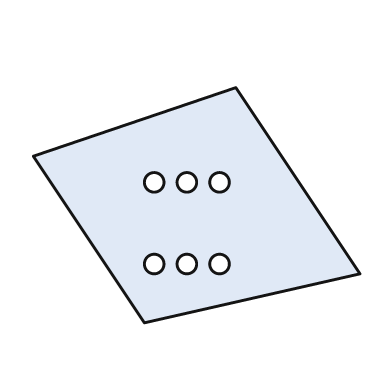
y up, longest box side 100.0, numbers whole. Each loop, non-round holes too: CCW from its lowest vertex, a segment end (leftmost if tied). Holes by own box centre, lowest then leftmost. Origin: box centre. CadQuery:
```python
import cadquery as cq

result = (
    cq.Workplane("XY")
    .moveTo(-16.0, -36.0)
    .lineTo(50.0, -21.0)
    .lineTo(12.0, 36.0)
    .lineTo(-50.0, 15.0)
    .close()
    .moveTo(-13.0, -18.0)
    .circle(3.0)
    .moveTo(-3.0, -18.0)
    .circle(3.0)
    .moveTo(7.0, -18.0)
    .circle(3.0)
    .moveTo(-13.0, 7.0)
    .circle(3.0)
    .moveTo(-3.0, 7.0)
    .circle(3.0)
    .moveTo(7.0, 7.0)
    .circle(3.0)
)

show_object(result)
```